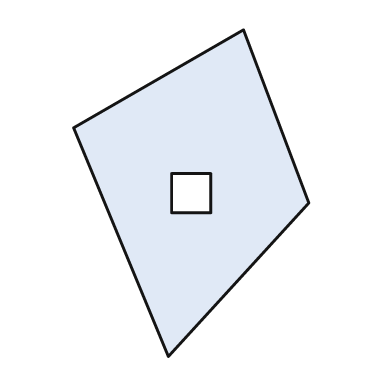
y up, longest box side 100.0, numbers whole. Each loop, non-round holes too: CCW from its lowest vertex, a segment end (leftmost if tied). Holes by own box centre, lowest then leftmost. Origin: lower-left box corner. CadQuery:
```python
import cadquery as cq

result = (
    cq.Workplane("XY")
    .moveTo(29.0, 0.0)
    .lineTo(72.0, 47.0)
    .lineTo(52.0, 100.0)
    .lineTo(0.0, 70.0)
    .close()
    .moveTo(30.0, 44.0)
    .lineTo(42.0, 44.0)
    .lineTo(42.0, 56.0)
    .lineTo(30.0, 56.0)
    .close()
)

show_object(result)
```